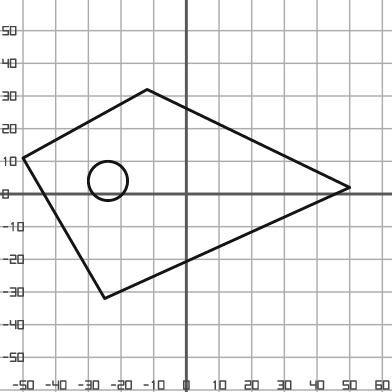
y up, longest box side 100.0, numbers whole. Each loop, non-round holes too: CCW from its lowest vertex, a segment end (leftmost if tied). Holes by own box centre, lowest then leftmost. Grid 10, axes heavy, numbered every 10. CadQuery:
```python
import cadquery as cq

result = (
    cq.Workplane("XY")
    .moveTo(-25.0, -32.0)
    .lineTo(50.0, 2.0)
    .lineTo(-12.0, 32.0)
    .lineTo(-50.0, 11.0)
    .close()
    .moveTo(-24.0, 4.0)
    .circle(6.0)
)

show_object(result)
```